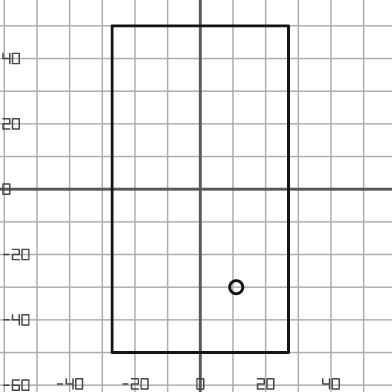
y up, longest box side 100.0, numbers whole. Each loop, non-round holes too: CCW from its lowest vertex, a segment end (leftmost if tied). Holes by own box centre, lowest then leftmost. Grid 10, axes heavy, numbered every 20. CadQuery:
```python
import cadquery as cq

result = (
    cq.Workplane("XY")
    .moveTo(-27.0, -50.0)
    .lineTo(27.0, -50.0)
    .lineTo(27.0, 50.0)
    .lineTo(-27.0, 50.0)
    .close()
    .moveTo(11.0, -30.0)
    .circle(2.0)
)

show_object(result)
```